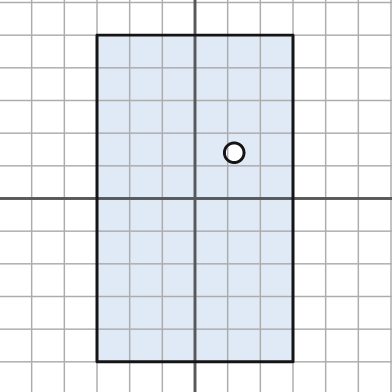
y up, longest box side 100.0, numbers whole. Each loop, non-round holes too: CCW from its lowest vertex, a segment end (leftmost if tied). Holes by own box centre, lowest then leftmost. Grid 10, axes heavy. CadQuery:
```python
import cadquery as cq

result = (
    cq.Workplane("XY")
    .moveTo(-30.0, -50.0)
    .lineTo(30.0, -50.0)
    .lineTo(30.0, 50.0)
    .lineTo(-30.0, 50.0)
    .close()
    .moveTo(12.0, 14.0)
    .circle(3.0)
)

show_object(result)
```